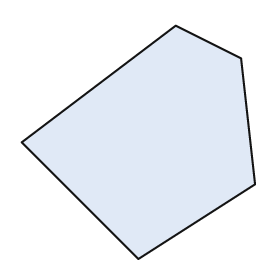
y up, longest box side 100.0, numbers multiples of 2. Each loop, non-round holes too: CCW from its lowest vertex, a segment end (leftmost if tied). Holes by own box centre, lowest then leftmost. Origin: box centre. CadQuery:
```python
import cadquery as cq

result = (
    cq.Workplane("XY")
    .moveTo(0.0, -50.0)
    .lineTo(50.0, -18.0)
    .lineTo(44.0, 36.0)
    .lineTo(16.0, 50.0)
    .lineTo(-50.0, 0.0)
    .close()
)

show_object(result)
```